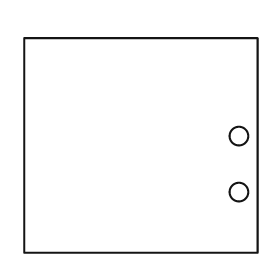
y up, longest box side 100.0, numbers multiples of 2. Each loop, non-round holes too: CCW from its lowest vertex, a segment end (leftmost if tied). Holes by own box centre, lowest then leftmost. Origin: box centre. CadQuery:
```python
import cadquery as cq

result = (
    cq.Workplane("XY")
    .moveTo(-50.0, -46.0)
    .lineTo(50.0, -46.0)
    .lineTo(50.0, 46.0)
    .lineTo(-50.0, 46.0)
    .close()
    .moveTo(42.0, -20.0)
    .circle(4.0)
    .moveTo(42.0, 4.0)
    .circle(4.0)
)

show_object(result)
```